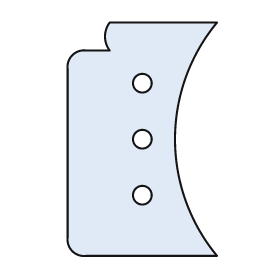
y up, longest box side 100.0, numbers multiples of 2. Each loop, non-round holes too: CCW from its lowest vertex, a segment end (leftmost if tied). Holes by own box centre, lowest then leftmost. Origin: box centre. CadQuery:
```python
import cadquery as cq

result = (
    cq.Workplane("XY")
    .moveTo(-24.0, -50.0)
    .lineTo(32.0, -50.0)
    .threePointArc((14.0, 0.0), (32.0, 50.0))
    .lineTo(-14.0, 50.0)
    .threePointArc((-16.0, 44.0), (-14.0, 38.0))
    .lineTo(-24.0, 38.0)
    .threePointArc((-30.0, 36.0), (-32.0, 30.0))
    .lineTo(-32.0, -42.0)
    .threePointArc((-30.0, -48.0), (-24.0, -50.0))
    .close()
    .moveTo(0.0, -24.0)
    .circle(4.0)
    .moveTo(0.0, 0.0)
    .circle(4.0)
    .moveTo(0.0, 24.0)
    .circle(4.0)
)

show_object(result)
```